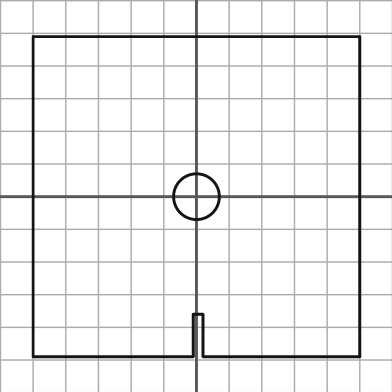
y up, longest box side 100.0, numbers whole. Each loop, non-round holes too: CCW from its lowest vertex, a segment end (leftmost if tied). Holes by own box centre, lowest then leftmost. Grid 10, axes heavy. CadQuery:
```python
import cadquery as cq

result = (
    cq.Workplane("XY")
    .moveTo(-50.0, -49.0)
    .lineTo(-1.0, -49.0)
    .lineTo(-1.0, -36.0)
    .lineTo(2.0, -36.0)
    .lineTo(2.0, -49.0)
    .lineTo(50.0, -49.0)
    .lineTo(50.0, 49.0)
    .lineTo(-50.0, 49.0)
    .close()
    .moveTo(0.0, 0.0)
    .circle(7.0)
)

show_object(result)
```